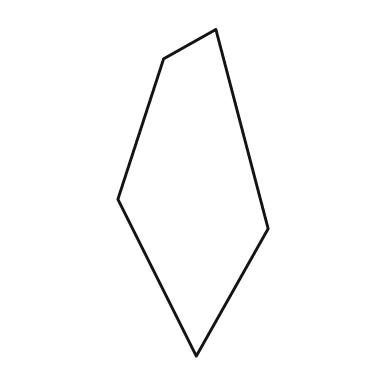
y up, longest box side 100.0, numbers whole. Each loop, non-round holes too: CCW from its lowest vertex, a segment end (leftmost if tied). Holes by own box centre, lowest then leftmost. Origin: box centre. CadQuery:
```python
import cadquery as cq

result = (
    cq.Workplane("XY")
    .moveTo(1.0, -50.0)
    .lineTo(23.0, -11.0)
    .lineTo(7.0, 50.0)
    .lineTo(-9.0, 41.0)
    .lineTo(-23.0, -2.0)
    .close()
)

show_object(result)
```